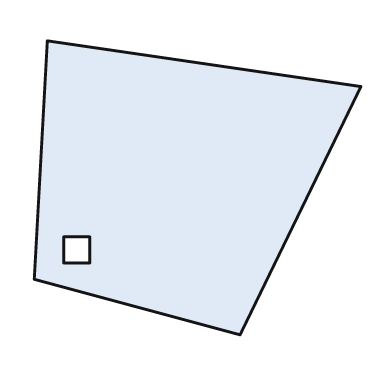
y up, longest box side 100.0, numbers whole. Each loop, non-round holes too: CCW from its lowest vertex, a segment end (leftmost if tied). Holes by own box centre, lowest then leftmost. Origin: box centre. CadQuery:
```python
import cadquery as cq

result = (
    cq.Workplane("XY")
    .moveTo(13.0, -45.0)
    .lineTo(50.0, 31.0)
    .lineTo(-46.0, 45.0)
    .lineTo(-50.0, -28.0)
    .close()
    .moveTo(-41.0, -23.0)
    .lineTo(-33.0, -23.0)
    .lineTo(-33.0, -15.0)
    .lineTo(-41.0, -15.0)
    .close()
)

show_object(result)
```